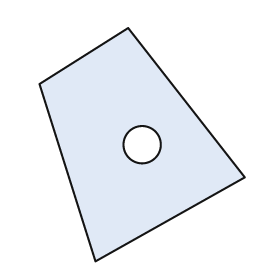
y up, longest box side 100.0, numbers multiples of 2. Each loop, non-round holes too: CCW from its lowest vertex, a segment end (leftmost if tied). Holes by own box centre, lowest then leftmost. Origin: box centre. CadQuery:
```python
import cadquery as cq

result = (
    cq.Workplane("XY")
    .moveTo(-20.0, -50.0)
    .lineTo(44.0, -14.0)
    .lineTo(-6.0, 50.0)
    .lineTo(-44.0, 26.0)
    .close()
    .moveTo(0.0, 0.0)
    .circle(8.0)
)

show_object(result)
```